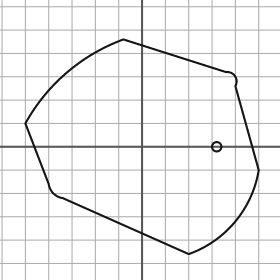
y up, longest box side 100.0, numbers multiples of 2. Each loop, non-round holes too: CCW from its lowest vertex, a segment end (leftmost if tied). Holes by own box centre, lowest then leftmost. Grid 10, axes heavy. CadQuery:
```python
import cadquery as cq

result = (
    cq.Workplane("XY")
    .moveTo(20.0, -46.0)
    .threePointArc((40.0, -32.0), (50.0, -10.0))
    .lineTo(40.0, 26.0)
    .threePointArc((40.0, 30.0), (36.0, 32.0))
    .lineTo(-8.0, 46.0)
    .threePointArc((-32.0, 32.0), (-50.0, 10.0))
    .lineTo(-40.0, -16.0)
    .threePointArc((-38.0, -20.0), (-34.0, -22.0))
    .close()
    .moveTo(32.0, 0.0)
    .circle(2.0)
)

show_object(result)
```